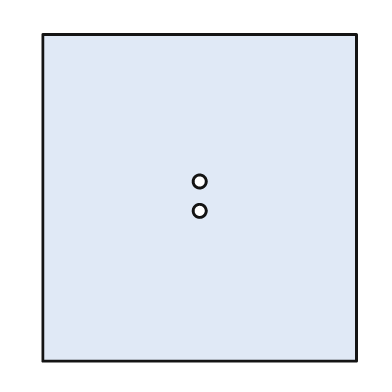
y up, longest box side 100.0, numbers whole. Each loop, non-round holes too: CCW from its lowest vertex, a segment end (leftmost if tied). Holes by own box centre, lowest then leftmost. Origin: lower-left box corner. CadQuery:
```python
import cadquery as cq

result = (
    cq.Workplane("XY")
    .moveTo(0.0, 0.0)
    .lineTo(96.0, 0.0)
    .lineTo(96.0, 100.0)
    .lineTo(0.0, 100.0)
    .close()
    .moveTo(48.0, 46.0)
    .circle(2.0)
    .moveTo(48.0, 55.0)
    .circle(2.0)
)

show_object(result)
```